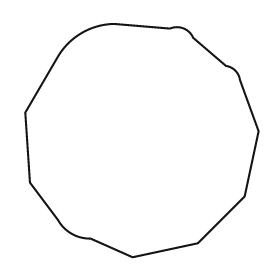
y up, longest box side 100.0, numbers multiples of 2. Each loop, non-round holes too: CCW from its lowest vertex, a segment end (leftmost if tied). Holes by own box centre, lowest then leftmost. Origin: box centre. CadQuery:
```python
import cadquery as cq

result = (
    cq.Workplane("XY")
    .moveTo(-4.0, -50.0)
    .lineTo(24.0, -44.0)
    .lineTo(44.0, -24.0)
    .lineTo(50.0, 4.0)
    .lineTo(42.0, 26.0)
    .threePointArc((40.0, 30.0), (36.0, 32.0))
    .lineTo(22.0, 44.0)
    .threePointArc((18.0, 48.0), (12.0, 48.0))
    .lineTo(-12.0, 50.0)
    .threePointArc((-26.0, 46.0), (-36.0, 36.0))
    .lineTo(-50.0, 12.0)
    .lineTo(-48.0, -18.0)
    .lineTo(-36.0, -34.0)
    .threePointArc((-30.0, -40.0), (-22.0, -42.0))
    .close()
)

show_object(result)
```